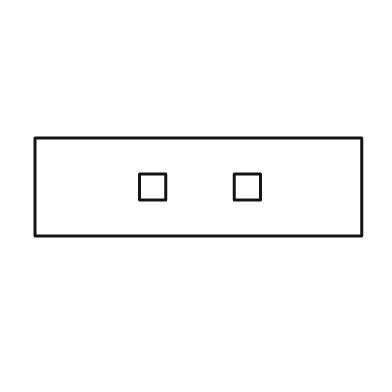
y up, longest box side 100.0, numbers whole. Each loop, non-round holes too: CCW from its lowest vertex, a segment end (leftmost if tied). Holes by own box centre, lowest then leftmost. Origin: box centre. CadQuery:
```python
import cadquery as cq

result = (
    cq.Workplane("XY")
    .moveTo(-50.0, -15.0)
    .lineTo(50.0, -15.0)
    .lineTo(50.0, 15.0)
    .lineTo(-50.0, 15.0)
    .close()
    .moveTo(-18.0, -4.0)
    .lineTo(-10.0, -4.0)
    .lineTo(-10.0, 4.0)
    .lineTo(-18.0, 4.0)
    .close()
    .moveTo(11.0, -4.0)
    .lineTo(19.0, -4.0)
    .lineTo(19.0, 4.0)
    .lineTo(11.0, 4.0)
    .close()
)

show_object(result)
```